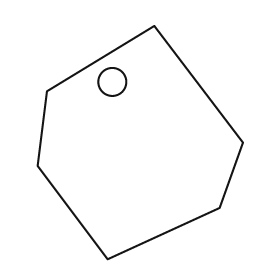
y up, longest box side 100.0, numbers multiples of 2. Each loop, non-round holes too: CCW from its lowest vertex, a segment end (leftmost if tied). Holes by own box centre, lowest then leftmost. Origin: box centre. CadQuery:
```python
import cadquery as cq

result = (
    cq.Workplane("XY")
    .moveTo(-14.0, -50.0)
    .lineTo(34.0, -28.0)
    .lineTo(44.0, 0.0)
    .lineTo(6.0, 50.0)
    .lineTo(-40.0, 22.0)
    .lineTo(-44.0, -10.0)
    .close()
    .moveTo(-12.0, 26.0)
    .circle(6.0)
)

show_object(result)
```